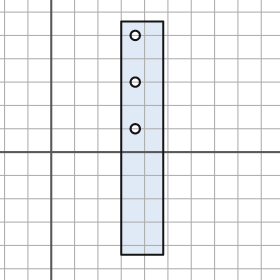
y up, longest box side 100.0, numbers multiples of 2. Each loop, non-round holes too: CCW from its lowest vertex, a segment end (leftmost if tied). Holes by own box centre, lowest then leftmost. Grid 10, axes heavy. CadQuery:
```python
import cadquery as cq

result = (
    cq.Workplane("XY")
    .moveTo(30.0, -44.0)
    .lineTo(48.0, -44.0)
    .lineTo(48.0, 56.0)
    .lineTo(30.0, 56.0)
    .close()
    .moveTo(36.0, 10.0)
    .circle(2.0)
    .moveTo(36.0, 30.0)
    .circle(2.0)
    .moveTo(36.0, 50.0)
    .circle(2.0)
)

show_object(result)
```